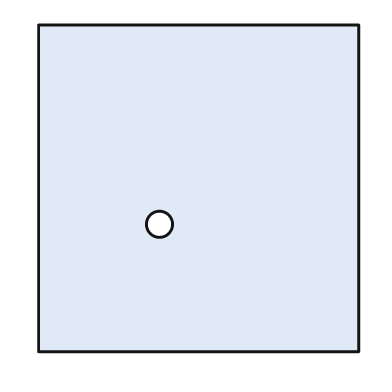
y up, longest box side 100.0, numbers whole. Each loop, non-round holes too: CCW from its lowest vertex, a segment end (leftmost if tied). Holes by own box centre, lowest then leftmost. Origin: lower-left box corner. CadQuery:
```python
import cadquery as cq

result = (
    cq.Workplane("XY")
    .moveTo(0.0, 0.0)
    .lineTo(98.0, 0.0)
    .lineTo(98.0, 100.0)
    .lineTo(0.0, 100.0)
    .close()
    .moveTo(37.0, 39.0)
    .circle(4.0)
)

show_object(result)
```